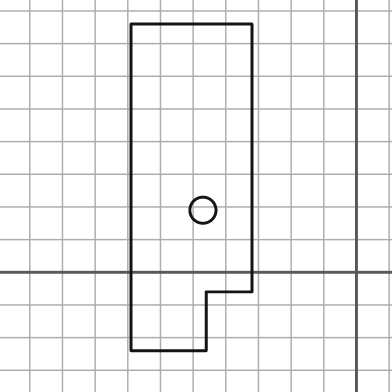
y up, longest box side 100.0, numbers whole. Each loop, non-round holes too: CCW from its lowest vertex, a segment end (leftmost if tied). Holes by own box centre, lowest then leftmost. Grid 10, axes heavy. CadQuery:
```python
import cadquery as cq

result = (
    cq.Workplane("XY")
    .moveTo(-69.0, -24.0)
    .lineTo(-46.0, -24.0)
    .lineTo(-46.0, -6.0)
    .lineTo(-32.0, -6.0)
    .lineTo(-32.0, 76.0)
    .lineTo(-69.0, 76.0)
    .close()
    .moveTo(-47.0, 19.0)
    .circle(4.0)
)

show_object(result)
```